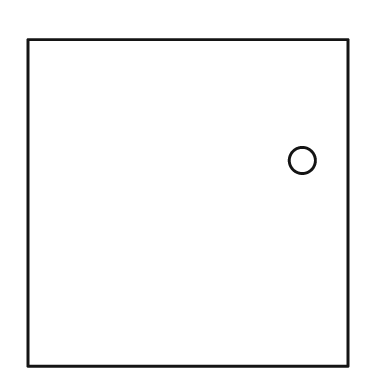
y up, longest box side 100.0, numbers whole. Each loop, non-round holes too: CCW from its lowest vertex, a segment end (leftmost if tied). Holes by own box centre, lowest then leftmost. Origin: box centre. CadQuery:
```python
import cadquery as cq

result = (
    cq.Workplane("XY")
    .moveTo(-49.0, -50.0)
    .lineTo(49.0, -50.0)
    .lineTo(49.0, 50.0)
    .lineTo(-49.0, 50.0)
    .close()
    .moveTo(35.0, 13.0)
    .circle(4.0)
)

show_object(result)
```